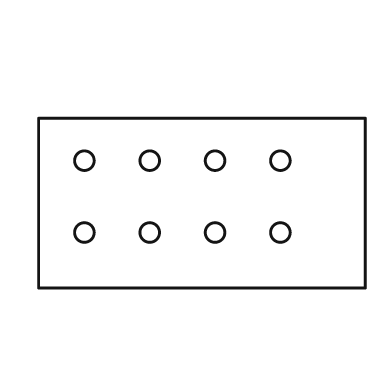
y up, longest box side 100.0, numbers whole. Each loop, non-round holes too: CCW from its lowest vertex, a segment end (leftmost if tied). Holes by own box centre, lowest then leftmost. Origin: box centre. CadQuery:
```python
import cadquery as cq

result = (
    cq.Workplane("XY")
    .moveTo(-50.0, -26.0)
    .lineTo(50.0, -26.0)
    .lineTo(50.0, 26.0)
    .lineTo(-50.0, 26.0)
    .close()
    .moveTo(-36.0, -9.0)
    .circle(3.0)
    .moveTo(-16.0, -9.0)
    .circle(3.0)
    .moveTo(4.0, -9.0)
    .circle(3.0)
    .moveTo(24.0, -9.0)
    .circle(3.0)
    .moveTo(-36.0, 13.0)
    .circle(3.0)
    .moveTo(-16.0, 13.0)
    .circle(3.0)
    .moveTo(4.0, 13.0)
    .circle(3.0)
    .moveTo(24.0, 13.0)
    .circle(3.0)
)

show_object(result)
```